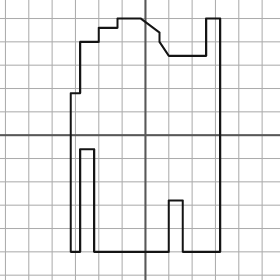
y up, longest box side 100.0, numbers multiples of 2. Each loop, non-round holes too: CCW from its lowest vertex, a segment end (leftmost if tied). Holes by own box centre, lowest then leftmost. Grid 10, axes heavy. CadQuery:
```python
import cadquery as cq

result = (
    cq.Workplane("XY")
    .moveTo(-32.0, -50.0)
    .lineTo(-28.0, -50.0)
    .lineTo(-28.0, -6.0)
    .lineTo(-22.0, -6.0)
    .lineTo(-22.0, -50.0)
    .lineTo(10.0, -50.0)
    .lineTo(10.0, -28.0)
    .lineTo(16.0, -28.0)
    .lineTo(16.0, -50.0)
    .lineTo(32.0, -50.0)
    .lineTo(32.0, 50.0)
    .lineTo(26.0, 50.0)
    .lineTo(26.0, 34.0)
    .lineTo(10.0, 34.0)
    .lineTo(6.0, 40.0)
    .lineTo(6.0, 44.0)
    .lineTo(-2.0, 50.0)
    .lineTo(-12.0, 50.0)
    .lineTo(-12.0, 46.0)
    .lineTo(-20.0, 46.0)
    .lineTo(-20.0, 40.0)
    .lineTo(-28.0, 40.0)
    .lineTo(-28.0, 18.0)
    .lineTo(-32.0, 18.0)
    .close()
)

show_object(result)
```